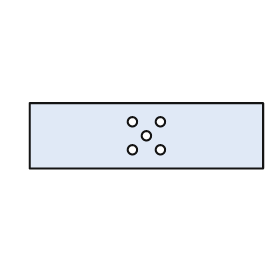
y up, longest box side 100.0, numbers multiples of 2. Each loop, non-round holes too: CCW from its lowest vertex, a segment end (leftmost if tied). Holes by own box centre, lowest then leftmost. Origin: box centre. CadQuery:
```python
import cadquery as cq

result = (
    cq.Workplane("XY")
    .moveTo(-50.0, -14.0)
    .lineTo(50.0, -14.0)
    .lineTo(50.0, 14.0)
    .lineTo(-50.0, 14.0)
    .close()
    .moveTo(-6.0, -6.0)
    .circle(2.0)
    .moveTo(6.0, -6.0)
    .circle(2.0)
    .moveTo(0.0, 0.0)
    .circle(2.0)
    .moveTo(-6.0, 6.0)
    .circle(2.0)
    .moveTo(6.0, 6.0)
    .circle(2.0)
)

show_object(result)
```